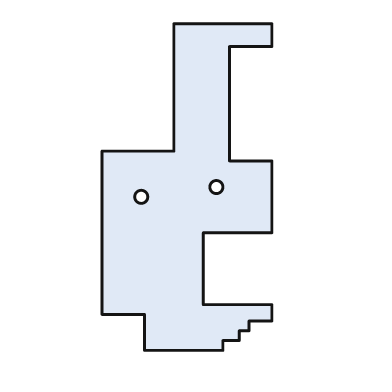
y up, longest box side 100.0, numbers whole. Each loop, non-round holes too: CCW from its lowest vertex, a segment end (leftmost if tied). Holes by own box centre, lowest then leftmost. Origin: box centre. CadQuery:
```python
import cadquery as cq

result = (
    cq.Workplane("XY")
    .moveTo(-13.0, -50.0)
    .lineTo(11.0, -50.0)
    .lineTo(11.0, -47.0)
    .lineTo(16.0, -47.0)
    .lineTo(16.0, -44.0)
    .lineTo(19.0, -44.0)
    .lineTo(19.0, -41.0)
    .lineTo(26.0, -41.0)
    .lineTo(26.0, -36.0)
    .lineTo(5.0, -36.0)
    .lineTo(5.0, -14.0)
    .lineTo(26.0, -14.0)
    .lineTo(26.0, 8.0)
    .lineTo(13.0, 8.0)
    .lineTo(13.0, 43.0)
    .lineTo(26.0, 43.0)
    .lineTo(26.0, 50.0)
    .lineTo(-4.0, 50.0)
    .lineTo(-4.0, 11.0)
    .lineTo(-26.0, 11.0)
    .lineTo(-26.0, -39.0)
    .lineTo(-13.0, -39.0)
    .close()
    .moveTo(-14.0, -3.0)
    .circle(2.0)
    .moveTo(9.0, 0.0)
    .circle(2.0)
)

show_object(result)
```